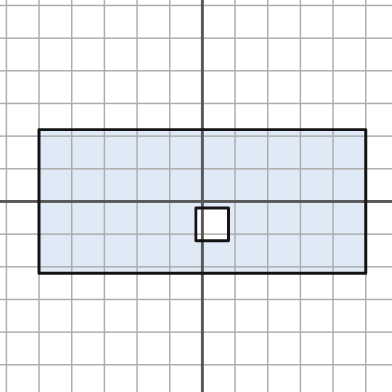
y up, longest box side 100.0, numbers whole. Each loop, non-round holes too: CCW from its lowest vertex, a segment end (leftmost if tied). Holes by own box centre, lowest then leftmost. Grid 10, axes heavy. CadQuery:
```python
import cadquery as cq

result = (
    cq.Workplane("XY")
    .moveTo(-50.0, -22.0)
    .lineTo(50.0, -22.0)
    .lineTo(50.0, 22.0)
    .lineTo(-50.0, 22.0)
    .close()
    .moveTo(-2.0, -12.0)
    .lineTo(8.0, -12.0)
    .lineTo(8.0, -2.0)
    .lineTo(-2.0, -2.0)
    .close()
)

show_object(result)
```